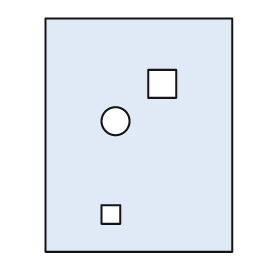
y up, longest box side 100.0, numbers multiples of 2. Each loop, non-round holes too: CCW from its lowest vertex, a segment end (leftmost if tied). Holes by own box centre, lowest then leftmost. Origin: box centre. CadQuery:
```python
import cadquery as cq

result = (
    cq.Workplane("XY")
    .moveTo(-40.0, -50.0)
    .lineTo(40.0, -50.0)
    .lineTo(40.0, 50.0)
    .lineTo(-40.0, 50.0)
    .close()
    .moveTo(-16.0, -38.0)
    .lineTo(-8.0, -38.0)
    .lineTo(-8.0, -30.0)
    .lineTo(-16.0, -30.0)
    .close()
    .moveTo(-10.0, 6.0)
    .circle(6.0)
    .moveTo(4.0, 16.0)
    .lineTo(16.0, 16.0)
    .lineTo(16.0, 28.0)
    .lineTo(4.0, 28.0)
    .close()
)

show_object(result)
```